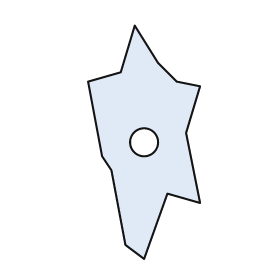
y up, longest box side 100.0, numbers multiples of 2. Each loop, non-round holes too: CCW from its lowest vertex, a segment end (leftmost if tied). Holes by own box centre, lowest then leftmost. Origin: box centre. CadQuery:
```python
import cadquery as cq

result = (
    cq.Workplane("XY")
    .moveTo(0.0, -50.0)
    .lineTo(10.0, -22.0)
    .lineTo(24.0, -26.0)
    .lineTo(18.0, 4.0)
    .lineTo(24.0, 24.0)
    .lineTo(14.0, 26.0)
    .lineTo(6.0, 34.0)
    .lineTo(-4.0, 50.0)
    .lineTo(-10.0, 30.0)
    .lineTo(-24.0, 26.0)
    .lineTo(-18.0, -6.0)
    .lineTo(-14.0, -12.0)
    .lineTo(-8.0, -44.0)
    .close()
    .moveTo(0.0, 0.0)
    .circle(6.0)
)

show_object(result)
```